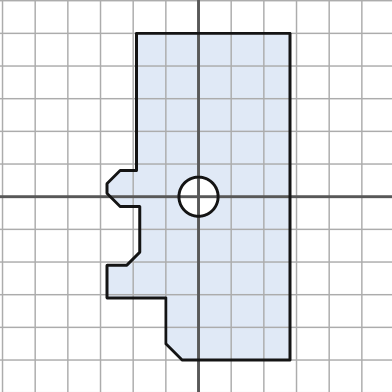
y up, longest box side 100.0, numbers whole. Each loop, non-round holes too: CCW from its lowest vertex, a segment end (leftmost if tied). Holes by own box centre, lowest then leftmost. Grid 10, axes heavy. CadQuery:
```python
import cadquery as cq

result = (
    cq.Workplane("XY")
    .moveTo(-5.0, -50.0)
    .lineTo(28.0, -50.0)
    .lineTo(28.0, 50.0)
    .lineTo(-19.0, 50.0)
    .lineTo(-19.0, 8.0)
    .lineTo(-24.0, 8.0)
    .lineTo(-28.0, 4.0)
    .lineTo(-28.0, 1.0)
    .lineTo(-24.0, -3.0)
    .lineTo(-18.0, -3.0)
    .lineTo(-18.0, -17.0)
    .lineTo(-22.0, -21.0)
    .lineTo(-28.0, -21.0)
    .lineTo(-28.0, -31.0)
    .lineTo(-10.0, -31.0)
    .lineTo(-10.0, -45.0)
    .close()
    .moveTo(0.0, 0.0)
    .circle(6.0)
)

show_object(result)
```